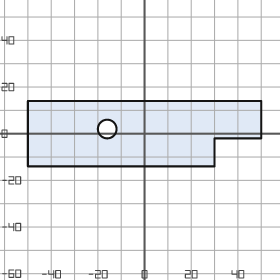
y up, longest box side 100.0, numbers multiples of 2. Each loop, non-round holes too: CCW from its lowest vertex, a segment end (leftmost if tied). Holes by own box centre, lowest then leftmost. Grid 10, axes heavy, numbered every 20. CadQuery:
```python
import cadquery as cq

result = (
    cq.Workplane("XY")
    .moveTo(-50.0, -14.0)
    .lineTo(30.0, -14.0)
    .lineTo(30.0, -2.0)
    .lineTo(50.0, -2.0)
    .lineTo(50.0, 14.0)
    .lineTo(-50.0, 14.0)
    .close()
    .moveTo(-16.0, 2.0)
    .circle(4.0)
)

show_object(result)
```